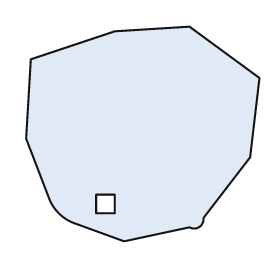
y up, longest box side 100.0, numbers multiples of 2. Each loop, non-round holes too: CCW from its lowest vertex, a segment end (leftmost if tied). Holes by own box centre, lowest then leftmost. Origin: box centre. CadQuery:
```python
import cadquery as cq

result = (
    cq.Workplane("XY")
    .moveTo(-8.0, -46.0)
    .lineTo(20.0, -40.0)
    .threePointArc((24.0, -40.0), (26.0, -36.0))
    .lineTo(46.0, -10.0)
    .lineTo(50.0, 24.0)
    .lineTo(20.0, 46.0)
    .lineTo(-12.0, 44.0)
    .lineTo(-48.0, 32.0)
    .lineTo(-50.0, -2.0)
    .lineTo(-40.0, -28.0)
    .threePointArc((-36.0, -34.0), (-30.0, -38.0))
    .close()
    .moveTo(-20.0, -34.0)
    .lineTo(-12.0, -34.0)
    .lineTo(-12.0, -26.0)
    .lineTo(-20.0, -26.0)
    .close()
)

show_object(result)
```